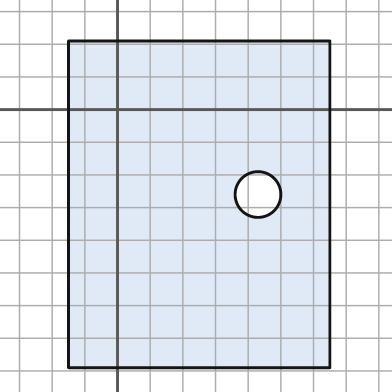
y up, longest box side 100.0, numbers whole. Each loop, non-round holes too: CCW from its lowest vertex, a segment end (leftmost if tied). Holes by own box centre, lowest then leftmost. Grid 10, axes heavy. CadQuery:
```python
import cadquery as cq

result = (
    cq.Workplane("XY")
    .moveTo(-15.0, -79.0)
    .lineTo(65.0, -79.0)
    .lineTo(65.0, 21.0)
    .lineTo(-15.0, 21.0)
    .close()
    .moveTo(43.0, -26.0)
    .circle(7.0)
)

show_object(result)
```